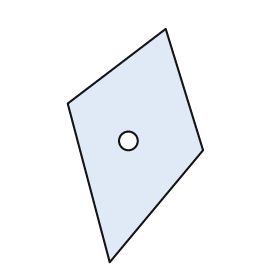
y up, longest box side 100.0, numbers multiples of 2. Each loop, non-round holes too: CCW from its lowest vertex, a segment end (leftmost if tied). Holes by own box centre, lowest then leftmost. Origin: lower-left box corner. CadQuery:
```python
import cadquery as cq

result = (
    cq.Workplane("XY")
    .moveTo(18.0, 0.0)
    .lineTo(58.0, 48.0)
    .lineTo(42.0, 100.0)
    .lineTo(0.0, 68.0)
    .close()
    .moveTo(26.0, 52.0)
    .circle(4.0)
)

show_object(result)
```